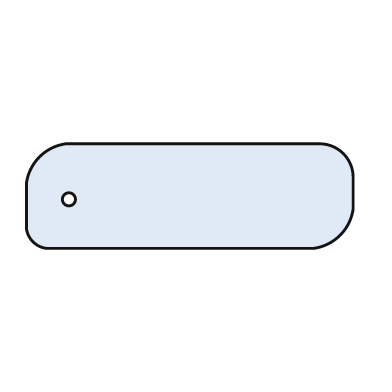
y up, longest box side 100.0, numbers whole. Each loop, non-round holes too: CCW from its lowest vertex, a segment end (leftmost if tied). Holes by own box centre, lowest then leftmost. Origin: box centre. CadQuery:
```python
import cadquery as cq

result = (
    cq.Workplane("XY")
    .moveTo(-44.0, -16.0)
    .lineTo(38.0, -16.0)
    .threePointArc((46.0, -12.0), (50.0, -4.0))
    .lineTo(50.0, 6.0)
    .threePointArc((47.0, 13.0), (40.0, 16.0))
    .lineTo(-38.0, 16.0)
    .threePointArc((-46.0, 12.0), (-50.0, 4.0))
    .lineTo(-50.0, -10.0)
    .threePointArc((-48.0, -14.0), (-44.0, -16.0))
    .close()
    .moveTo(-37.0, -1.0)
    .circle(2.0)
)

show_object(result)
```